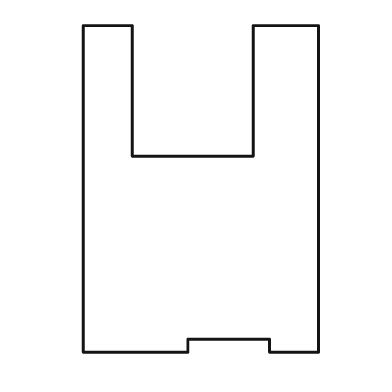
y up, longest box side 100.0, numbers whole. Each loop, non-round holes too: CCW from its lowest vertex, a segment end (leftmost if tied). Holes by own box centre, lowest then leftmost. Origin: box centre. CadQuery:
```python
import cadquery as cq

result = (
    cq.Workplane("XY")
    .moveTo(-36.0, -50.0)
    .lineTo(-4.0, -50.0)
    .lineTo(-4.0, -46.0)
    .lineTo(21.0, -46.0)
    .lineTo(21.0, -50.0)
    .lineTo(36.0, -50.0)
    .lineTo(36.0, 50.0)
    .lineTo(16.0, 50.0)
    .lineTo(16.0, 10.0)
    .lineTo(-21.0, 10.0)
    .lineTo(-21.0, 50.0)
    .lineTo(-36.0, 50.0)
    .close()
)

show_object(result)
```